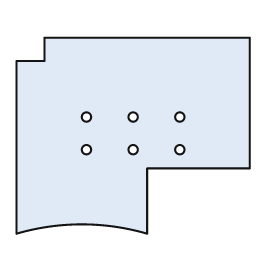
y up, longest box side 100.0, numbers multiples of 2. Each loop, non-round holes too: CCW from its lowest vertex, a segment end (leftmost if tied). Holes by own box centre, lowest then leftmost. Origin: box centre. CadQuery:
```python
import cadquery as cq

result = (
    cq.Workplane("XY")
    .moveTo(-50.0, -42.0)
    .threePointArc((-22.0, -38.0), (6.0, -42.0))
    .lineTo(6.0, -14.0)
    .lineTo(50.0, -14.0)
    .lineTo(50.0, 42.0)
    .lineTo(-38.0, 42.0)
    .lineTo(-38.0, 32.0)
    .lineTo(-50.0, 32.0)
    .close()
    .moveTo(-20.0, -6.0)
    .circle(2.0)
    .moveTo(0.0, -6.0)
    .circle(2.0)
    .moveTo(20.0, -6.0)
    .circle(2.0)
    .moveTo(-20.0, 8.0)
    .circle(2.0)
    .moveTo(0.0, 8.0)
    .circle(2.0)
    .moveTo(20.0, 8.0)
    .circle(2.0)
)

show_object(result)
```